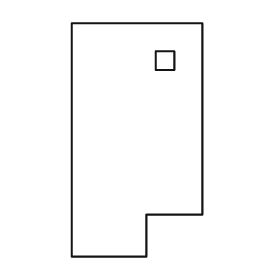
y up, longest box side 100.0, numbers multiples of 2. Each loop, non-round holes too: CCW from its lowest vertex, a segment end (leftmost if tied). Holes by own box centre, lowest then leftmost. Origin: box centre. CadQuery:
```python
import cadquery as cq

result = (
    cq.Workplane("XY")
    .moveTo(-28.0, -50.0)
    .lineTo(4.0, -50.0)
    .lineTo(4.0, -32.0)
    .lineTo(28.0, -32.0)
    .lineTo(28.0, 50.0)
    .lineTo(-28.0, 50.0)
    .close()
    .moveTo(8.0, 30.0)
    .lineTo(16.0, 30.0)
    .lineTo(16.0, 38.0)
    .lineTo(8.0, 38.0)
    .close()
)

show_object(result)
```